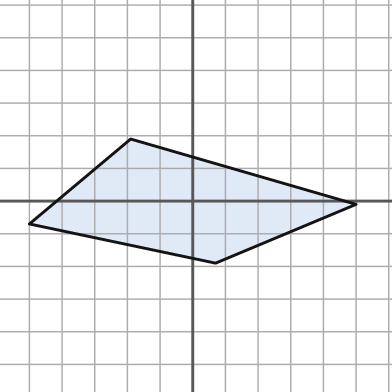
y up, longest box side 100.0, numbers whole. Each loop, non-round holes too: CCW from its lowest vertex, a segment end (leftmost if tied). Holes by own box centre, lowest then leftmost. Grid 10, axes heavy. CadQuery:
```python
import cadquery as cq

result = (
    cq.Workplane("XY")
    .moveTo(7.0, -19.0)
    .lineTo(50.0, -1.0)
    .lineTo(-19.0, 19.0)
    .lineTo(-50.0, -7.0)
    .close()
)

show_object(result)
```